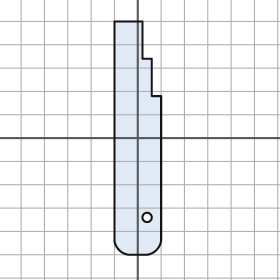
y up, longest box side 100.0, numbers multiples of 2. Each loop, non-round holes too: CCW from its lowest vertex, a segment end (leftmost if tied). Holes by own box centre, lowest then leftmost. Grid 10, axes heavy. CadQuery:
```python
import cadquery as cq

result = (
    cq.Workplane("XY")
    .moveTo(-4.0, -50.0)
    .lineTo(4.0, -50.0)
    .threePointArc((8.0, -48.0), (10.0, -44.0))
    .lineTo(10.0, 18.0)
    .lineTo(6.0, 18.0)
    .lineTo(6.0, 34.0)
    .lineTo(2.0, 34.0)
    .lineTo(2.0, 50.0)
    .lineTo(-10.0, 50.0)
    .lineTo(-10.0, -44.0)
    .threePointArc((-8.0, -48.0), (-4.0, -50.0))
    .close()
    .moveTo(4.0, -34.0)
    .circle(2.0)
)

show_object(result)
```